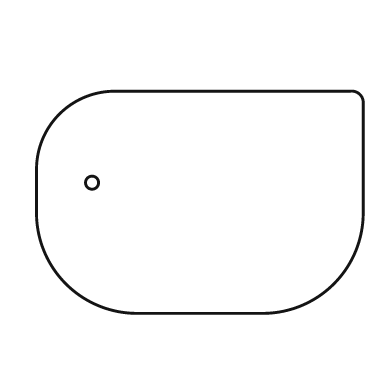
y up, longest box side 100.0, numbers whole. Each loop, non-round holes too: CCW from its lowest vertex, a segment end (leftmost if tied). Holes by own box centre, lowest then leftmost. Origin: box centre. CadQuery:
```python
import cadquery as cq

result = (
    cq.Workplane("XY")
    .moveTo(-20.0, -34.0)
    .lineTo(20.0, -34.0)
    .threePointArc((41.0, -25.0), (50.0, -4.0))
    .lineTo(50.0, 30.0)
    .threePointArc((49.0, 33.0), (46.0, 34.0))
    .lineTo(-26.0, 34.0)
    .threePointArc((-43.0, 27.0), (-50.0, 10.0))
    .lineTo(-50.0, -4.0)
    .threePointArc((-41.0, -25.0), (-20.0, -34.0))
    .close()
    .moveTo(-33.0, 6.0)
    .circle(2.0)
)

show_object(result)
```